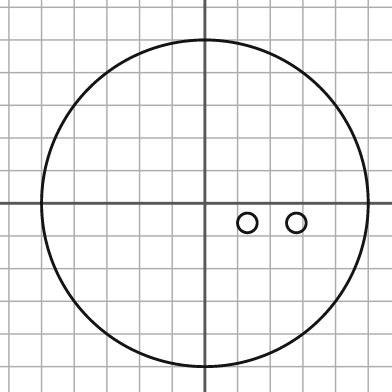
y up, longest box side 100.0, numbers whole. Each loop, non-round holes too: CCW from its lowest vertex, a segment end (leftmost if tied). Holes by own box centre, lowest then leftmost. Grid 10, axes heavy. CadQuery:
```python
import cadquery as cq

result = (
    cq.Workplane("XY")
    .moveTo(0.0, 0.0)
    .circle(50.0)
    .moveTo(13.0, -6.0)
    .circle(3.0)
    .moveTo(28.0, -6.0)
    .circle(3.0)
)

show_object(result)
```